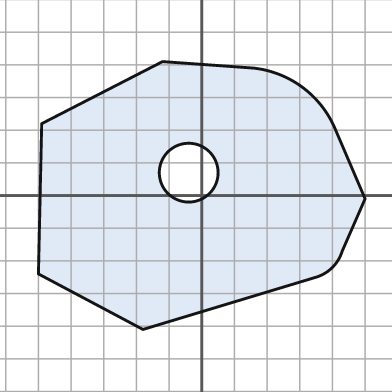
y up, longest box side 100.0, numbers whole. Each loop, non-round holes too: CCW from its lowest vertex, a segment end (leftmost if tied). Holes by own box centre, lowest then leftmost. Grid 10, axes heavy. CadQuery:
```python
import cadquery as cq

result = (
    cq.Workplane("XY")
    .moveTo(-18.0, -41.0)
    .lineTo(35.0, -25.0)
    .threePointArc((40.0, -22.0), (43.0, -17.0))
    .lineTo(50.0, -1.0)
    .lineTo(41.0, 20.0)
    .threePointArc((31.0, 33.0), (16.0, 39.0))
    .lineTo(-12.0, 41.0)
    .lineTo(-49.0, 22.0)
    .lineTo(-50.0, -24.0)
    .close()
    .moveTo(-4.0, 7.0)
    .circle(9.0)
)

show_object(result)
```